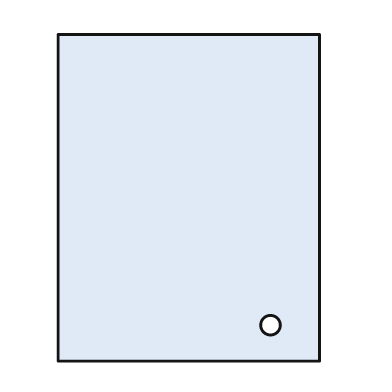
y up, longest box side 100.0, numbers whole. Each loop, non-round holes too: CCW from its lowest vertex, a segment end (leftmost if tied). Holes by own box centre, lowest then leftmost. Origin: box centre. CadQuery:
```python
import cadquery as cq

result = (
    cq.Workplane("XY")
    .moveTo(-40.0, -50.0)
    .lineTo(40.0, -50.0)
    .lineTo(40.0, 50.0)
    .lineTo(-40.0, 50.0)
    .close()
    .moveTo(25.0, -39.0)
    .circle(3.0)
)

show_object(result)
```